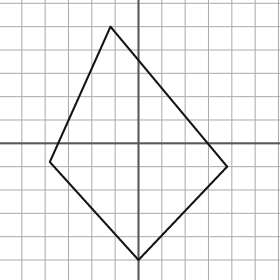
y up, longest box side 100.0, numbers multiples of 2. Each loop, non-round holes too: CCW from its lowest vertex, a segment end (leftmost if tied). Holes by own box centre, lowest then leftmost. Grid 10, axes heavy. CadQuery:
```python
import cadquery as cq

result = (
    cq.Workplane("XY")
    .moveTo(0.0, -50.0)
    .lineTo(38.0, -10.0)
    .lineTo(-12.0, 50.0)
    .lineTo(-38.0, -8.0)
    .close()
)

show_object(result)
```